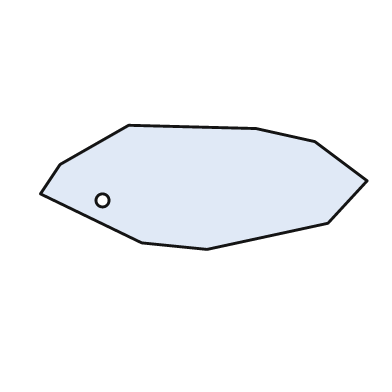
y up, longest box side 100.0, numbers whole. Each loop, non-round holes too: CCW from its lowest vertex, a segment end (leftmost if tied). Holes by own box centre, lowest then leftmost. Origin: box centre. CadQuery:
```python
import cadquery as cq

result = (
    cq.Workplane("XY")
    .moveTo(1.0, -19.0)
    .lineTo(38.0, -11.0)
    .lineTo(50.0, 2.0)
    .lineTo(34.0, 14.0)
    .lineTo(16.0, 18.0)
    .lineTo(-23.0, 19.0)
    .lineTo(-44.0, 7.0)
    .lineTo(-50.0, -2.0)
    .lineTo(-19.0, -17.0)
    .close()
    .moveTo(-31.0, -4.0)
    .circle(2.0)
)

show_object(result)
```